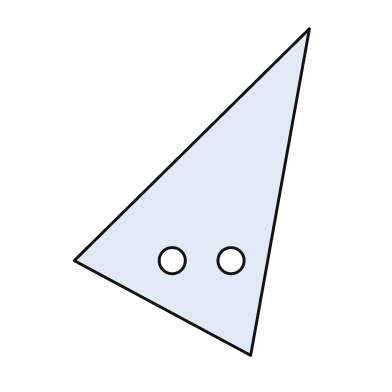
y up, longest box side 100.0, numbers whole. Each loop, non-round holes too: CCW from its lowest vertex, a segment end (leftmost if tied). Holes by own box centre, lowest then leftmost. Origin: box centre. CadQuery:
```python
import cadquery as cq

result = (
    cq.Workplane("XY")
    .moveTo(18.0, -50.0)
    .lineTo(36.0, 50.0)
    .lineTo(-36.0, -21.0)
    .close()
    .moveTo(-6.0, -21.0)
    .circle(4.0)
    .moveTo(12.0, -21.0)
    .circle(4.0)
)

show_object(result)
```